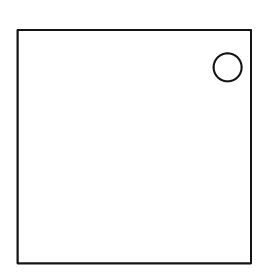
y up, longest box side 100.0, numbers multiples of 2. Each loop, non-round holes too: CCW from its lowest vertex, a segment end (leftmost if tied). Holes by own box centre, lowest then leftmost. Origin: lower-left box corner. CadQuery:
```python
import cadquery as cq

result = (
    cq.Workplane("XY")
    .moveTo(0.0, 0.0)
    .lineTo(100.0, 0.0)
    .lineTo(100.0, 100.0)
    .lineTo(0.0, 100.0)
    .close()
    .moveTo(90.0, 84.0)
    .circle(6.0)
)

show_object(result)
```